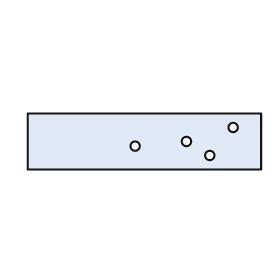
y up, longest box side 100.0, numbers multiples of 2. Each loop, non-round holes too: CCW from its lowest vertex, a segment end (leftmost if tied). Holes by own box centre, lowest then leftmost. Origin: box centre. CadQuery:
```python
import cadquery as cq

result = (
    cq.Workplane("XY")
    .moveTo(-50.0, -12.0)
    .lineTo(50.0, -12.0)
    .lineTo(50.0, 12.0)
    .lineTo(-50.0, 12.0)
    .close()
    .moveTo(28.0, -6.0)
    .circle(2.0)
    .moveTo(-4.0, -2.0)
    .circle(2.0)
    .moveTo(18.0, 0.0)
    .circle(2.0)
    .moveTo(38.0, 6.0)
    .circle(2.0)
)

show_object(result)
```